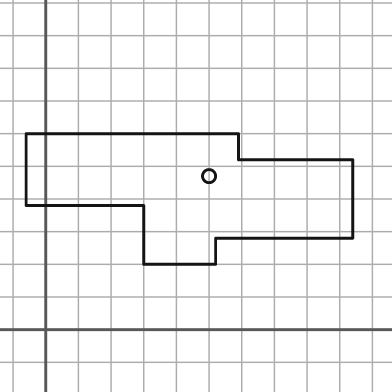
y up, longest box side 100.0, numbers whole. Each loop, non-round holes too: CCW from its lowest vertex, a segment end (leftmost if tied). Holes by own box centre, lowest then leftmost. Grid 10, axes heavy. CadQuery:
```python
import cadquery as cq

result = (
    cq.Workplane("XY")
    .moveTo(30.0, 20.0)
    .lineTo(52.0, 20.0)
    .lineTo(52.0, 28.0)
    .lineTo(94.0, 28.0)
    .lineTo(94.0, 52.0)
    .lineTo(59.0, 52.0)
    .lineTo(59.0, 60.0)
    .lineTo(-6.0, 60.0)
    .lineTo(-6.0, 38.0)
    .lineTo(30.0, 38.0)
    .close()
    .moveTo(50.0, 47.0)
    .circle(2.0)
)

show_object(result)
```